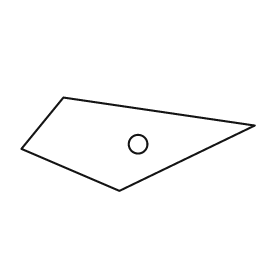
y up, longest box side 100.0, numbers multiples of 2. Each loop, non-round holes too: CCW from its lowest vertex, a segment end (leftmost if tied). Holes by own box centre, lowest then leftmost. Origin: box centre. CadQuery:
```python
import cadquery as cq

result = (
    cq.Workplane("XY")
    .moveTo(-8.0, -20.0)
    .lineTo(50.0, 8.0)
    .lineTo(-32.0, 20.0)
    .lineTo(-50.0, -2.0)
    .close()
    .moveTo(0.0, 0.0)
    .circle(4.0)
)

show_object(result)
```